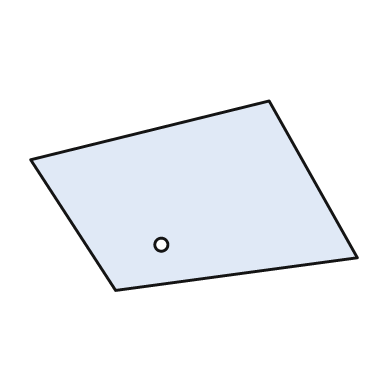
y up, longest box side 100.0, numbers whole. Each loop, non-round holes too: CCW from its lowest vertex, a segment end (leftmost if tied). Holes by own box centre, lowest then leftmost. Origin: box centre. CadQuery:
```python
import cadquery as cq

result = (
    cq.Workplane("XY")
    .moveTo(-24.0, -29.0)
    .lineTo(50.0, -19.0)
    .lineTo(23.0, 29.0)
    .lineTo(-50.0, 11.0)
    .close()
    .moveTo(-10.0, -15.0)
    .circle(2.0)
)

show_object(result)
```